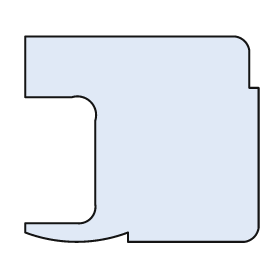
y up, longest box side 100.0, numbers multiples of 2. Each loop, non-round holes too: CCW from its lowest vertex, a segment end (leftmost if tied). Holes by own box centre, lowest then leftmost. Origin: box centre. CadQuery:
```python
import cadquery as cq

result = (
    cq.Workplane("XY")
    .moveTo(-6.0, -44.0)
    .lineTo(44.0, -44.0)
    .threePointArc((48.0, -42.0), (50.0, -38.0))
    .lineTo(50.0, 22.0)
    .lineTo(46.0, 22.0)
    .lineTo(46.0, 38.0)
    .threePointArc((44.0, 42.0), (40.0, 44.0))
    .lineTo(-50.0, 44.0)
    .lineTo(-50.0, 18.0)
    .lineTo(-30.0, 18.0)
    .threePointArc((-22.0, 16.0), (-20.0, 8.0))
    .lineTo(-20.0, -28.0)
    .threePointArc((-22.0, -34.0), (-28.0, -36.0))
    .lineTo(-50.0, -36.0)
    .lineTo(-50.0, -40.0)
    .threePointArc((-28.0, -44.0), (-6.0, -40.0))
    .close()
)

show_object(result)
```